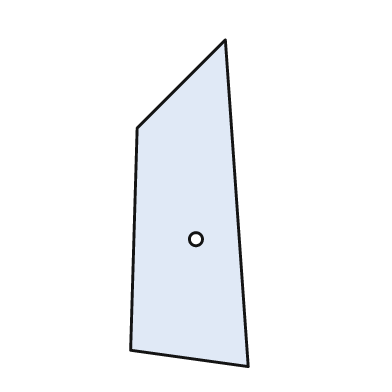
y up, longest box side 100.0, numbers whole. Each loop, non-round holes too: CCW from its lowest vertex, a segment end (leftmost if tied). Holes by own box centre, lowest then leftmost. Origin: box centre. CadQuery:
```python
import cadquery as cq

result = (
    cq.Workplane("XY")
    .moveTo(18.0, -50.0)
    .lineTo(11.0, 50.0)
    .lineTo(-16.0, 23.0)
    .lineTo(-18.0, -45.0)
    .close()
    .moveTo(2.0, -11.0)
    .circle(2.0)
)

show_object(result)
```